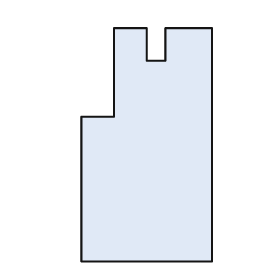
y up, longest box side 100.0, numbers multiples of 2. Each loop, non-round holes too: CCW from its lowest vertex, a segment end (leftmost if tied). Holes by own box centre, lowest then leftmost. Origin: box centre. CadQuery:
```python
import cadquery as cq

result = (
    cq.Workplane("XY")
    .moveTo(-28.0, -50.0)
    .lineTo(28.0, -50.0)
    .lineTo(28.0, 50.0)
    .lineTo(8.0, 50.0)
    .lineTo(8.0, 36.0)
    .lineTo(0.0, 36.0)
    .lineTo(0.0, 50.0)
    .lineTo(-14.0, 50.0)
    .lineTo(-14.0, 12.0)
    .lineTo(-28.0, 12.0)
    .close()
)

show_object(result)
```